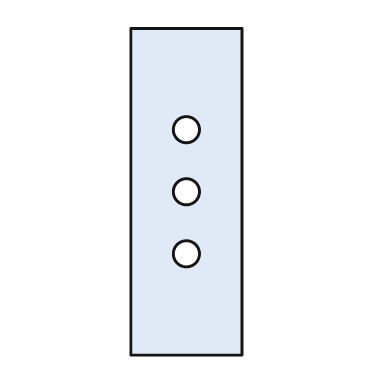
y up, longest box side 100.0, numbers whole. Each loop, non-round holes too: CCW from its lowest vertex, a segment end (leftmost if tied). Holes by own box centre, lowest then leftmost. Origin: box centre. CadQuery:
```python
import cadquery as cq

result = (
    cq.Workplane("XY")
    .moveTo(-17.0, -50.0)
    .lineTo(17.0, -50.0)
    .lineTo(17.0, 50.0)
    .lineTo(-17.0, 50.0)
    .close()
    .moveTo(0.0, -19.0)
    .circle(4.0)
    .moveTo(0.0, 0.0)
    .circle(4.0)
    .moveTo(0.0, 19.0)
    .circle(4.0)
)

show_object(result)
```